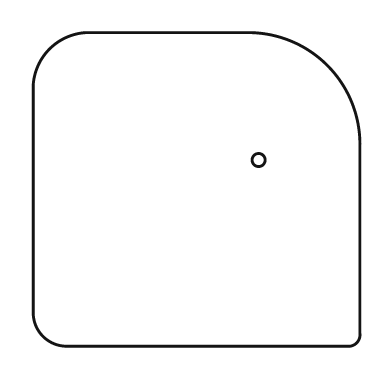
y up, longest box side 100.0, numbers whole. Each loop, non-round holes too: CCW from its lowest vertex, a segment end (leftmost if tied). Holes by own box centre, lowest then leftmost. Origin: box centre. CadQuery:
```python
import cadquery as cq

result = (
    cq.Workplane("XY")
    .moveTo(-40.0, -48.0)
    .lineTo(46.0, -48.0)
    .threePointArc((49.0, -47.0), (50.0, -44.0))
    .lineTo(50.0, 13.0)
    .threePointArc((40.0, 38.0), (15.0, 48.0))
    .lineTo(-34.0, 48.0)
    .threePointArc((-45.0, 43.0), (-50.0, 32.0))
    .lineTo(-50.0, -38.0)
    .threePointArc((-47.0, -45.0), (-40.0, -48.0))
    .close()
    .moveTo(19.0, 9.0)
    .circle(2.0)
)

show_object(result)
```